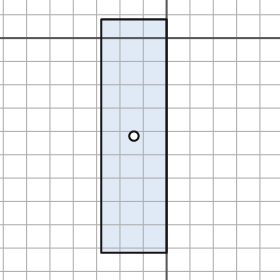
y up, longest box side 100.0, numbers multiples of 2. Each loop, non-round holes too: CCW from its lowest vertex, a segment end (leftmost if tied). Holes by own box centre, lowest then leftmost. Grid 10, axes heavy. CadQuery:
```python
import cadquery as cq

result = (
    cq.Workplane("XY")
    .moveTo(-28.0, -92.0)
    .lineTo(0.0, -92.0)
    .lineTo(0.0, 8.0)
    .lineTo(-28.0, 8.0)
    .close()
    .moveTo(-14.0, -42.0)
    .circle(2.0)
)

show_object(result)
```